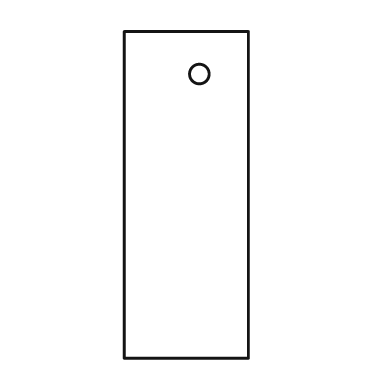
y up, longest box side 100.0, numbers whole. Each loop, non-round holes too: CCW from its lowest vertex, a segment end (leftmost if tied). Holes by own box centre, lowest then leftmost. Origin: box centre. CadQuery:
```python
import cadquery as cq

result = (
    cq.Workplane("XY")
    .moveTo(-19.0, -50.0)
    .lineTo(19.0, -50.0)
    .lineTo(19.0, 50.0)
    .lineTo(-19.0, 50.0)
    .close()
    .moveTo(4.0, 37.0)
    .circle(3.0)
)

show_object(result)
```